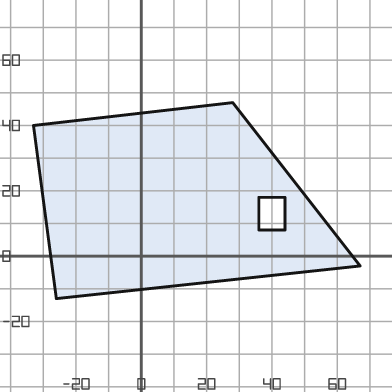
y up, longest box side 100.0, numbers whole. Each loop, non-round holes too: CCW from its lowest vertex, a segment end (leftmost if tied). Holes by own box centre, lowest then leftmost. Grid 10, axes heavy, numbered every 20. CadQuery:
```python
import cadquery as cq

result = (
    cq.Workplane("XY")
    .moveTo(-26.0, -13.0)
    .lineTo(67.0, -3.0)
    .lineTo(28.0, 47.0)
    .lineTo(-33.0, 40.0)
    .close()
    .moveTo(36.0, 8.0)
    .lineTo(44.0, 8.0)
    .lineTo(44.0, 18.0)
    .lineTo(36.0, 18.0)
    .close()
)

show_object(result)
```